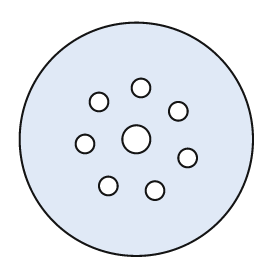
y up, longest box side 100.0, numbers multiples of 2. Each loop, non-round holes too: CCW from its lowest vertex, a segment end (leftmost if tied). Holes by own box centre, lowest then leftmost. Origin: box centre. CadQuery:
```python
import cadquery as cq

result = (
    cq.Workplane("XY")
    .moveTo(0.0, 0.0)
    .circle(50.0)
    .moveTo(8.0, -22.0)
    .circle(4.0)
    .moveTo(-12.0, -20.0)
    .circle(4.0)
    .moveTo(22.0, -8.0)
    .circle(4.0)
    .moveTo(-22.0, -2.0)
    .circle(4.0)
    .moveTo(0.0, 0.0)
    .circle(6.0)
    .moveTo(18.0, 12.0)
    .circle(4.0)
    .moveTo(-16.0, 16.0)
    .circle(4.0)
    .moveTo(2.0, 22.0)
    .circle(4.0)
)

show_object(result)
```